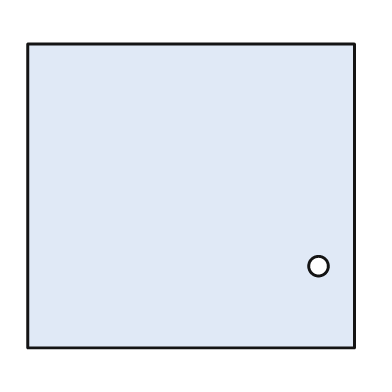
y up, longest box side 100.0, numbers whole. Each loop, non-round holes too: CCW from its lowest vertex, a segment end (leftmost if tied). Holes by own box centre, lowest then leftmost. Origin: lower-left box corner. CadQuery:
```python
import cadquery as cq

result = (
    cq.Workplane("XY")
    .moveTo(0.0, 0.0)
    .lineTo(100.0, 0.0)
    .lineTo(100.0, 93.0)
    .lineTo(0.0, 93.0)
    .close()
    .moveTo(89.0, 25.0)
    .circle(3.0)
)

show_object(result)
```